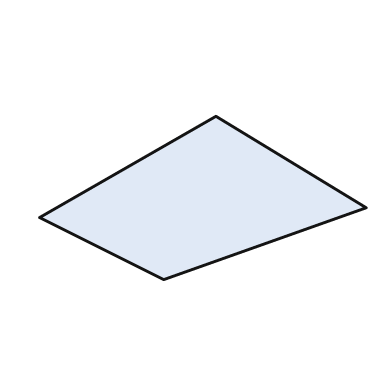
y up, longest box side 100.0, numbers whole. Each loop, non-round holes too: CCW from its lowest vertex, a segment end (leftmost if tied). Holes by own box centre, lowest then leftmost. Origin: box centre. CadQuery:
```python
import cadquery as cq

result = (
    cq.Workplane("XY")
    .moveTo(-12.0, -25.0)
    .lineTo(50.0, -3.0)
    .lineTo(4.0, 25.0)
    .lineTo(-50.0, -6.0)
    .close()
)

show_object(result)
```